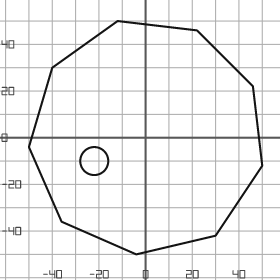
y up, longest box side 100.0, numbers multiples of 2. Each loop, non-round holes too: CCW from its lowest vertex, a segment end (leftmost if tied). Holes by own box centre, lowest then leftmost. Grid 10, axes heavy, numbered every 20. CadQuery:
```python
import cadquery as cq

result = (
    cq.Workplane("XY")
    .moveTo(-4.0, -50.0)
    .lineTo(30.0, -42.0)
    .lineTo(50.0, -12.0)
    .lineTo(46.0, 22.0)
    .lineTo(22.0, 46.0)
    .lineTo(-12.0, 50.0)
    .lineTo(-40.0, 30.0)
    .lineTo(-50.0, -4.0)
    .lineTo(-36.0, -36.0)
    .close()
    .moveTo(-22.0, -10.0)
    .circle(6.0)
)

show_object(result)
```